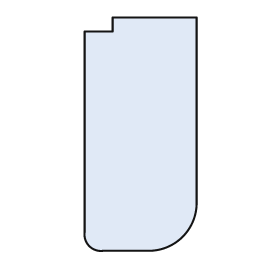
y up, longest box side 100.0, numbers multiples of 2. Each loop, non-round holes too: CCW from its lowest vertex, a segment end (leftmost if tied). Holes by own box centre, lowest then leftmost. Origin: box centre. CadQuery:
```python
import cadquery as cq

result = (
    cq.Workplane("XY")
    .moveTo(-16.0, -50.0)
    .lineTo(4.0, -50.0)
    .threePointArc((18.0, -44.0), (24.0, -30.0))
    .lineTo(24.0, 50.0)
    .lineTo(-12.0, 50.0)
    .lineTo(-12.0, 44.0)
    .lineTo(-24.0, 44.0)
    .lineTo(-24.0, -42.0)
    .threePointArc((-22.0, -48.0), (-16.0, -50.0))
    .close()
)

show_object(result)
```